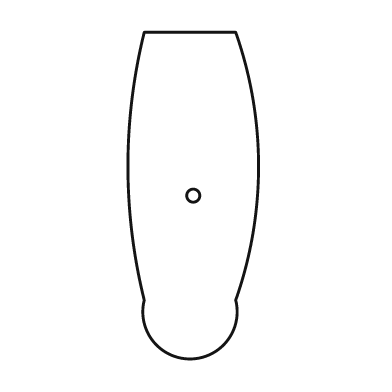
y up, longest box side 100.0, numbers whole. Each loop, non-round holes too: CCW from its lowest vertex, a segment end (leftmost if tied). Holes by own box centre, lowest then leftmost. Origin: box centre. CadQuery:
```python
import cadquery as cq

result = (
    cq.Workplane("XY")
    .moveTo(-15.0, -32.0)
    .threePointArc((-1.0, -50.0), (13.0, -32.0))
    .threePointArc((20.0, 9.0), (13.0, 50.0))
    .lineTo(-15.0, 50.0)
    .threePointArc((-20.0, 9.0), (-15.0, -32.0))
    .close()
    .moveTo(0.0, 0.0)
    .circle(2.0)
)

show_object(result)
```